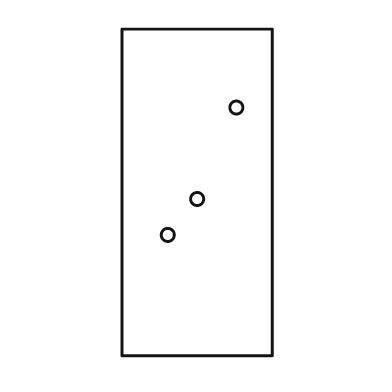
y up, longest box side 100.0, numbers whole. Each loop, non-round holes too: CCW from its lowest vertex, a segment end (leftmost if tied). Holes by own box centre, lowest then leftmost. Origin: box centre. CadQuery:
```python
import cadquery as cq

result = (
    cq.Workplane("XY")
    .moveTo(-23.0, -50.0)
    .lineTo(23.0, -50.0)
    .lineTo(23.0, 50.0)
    .lineTo(-23.0, 50.0)
    .close()
    .moveTo(-9.0, -13.0)
    .circle(2.0)
    .moveTo(0.0, -2.0)
    .circle(2.0)
    .moveTo(12.0, 26.0)
    .circle(2.0)
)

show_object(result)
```